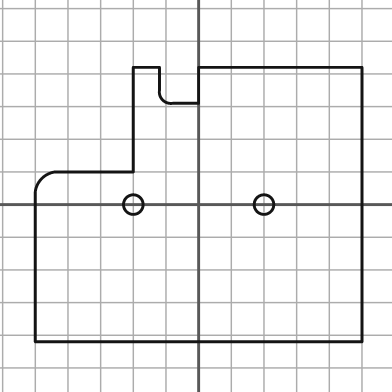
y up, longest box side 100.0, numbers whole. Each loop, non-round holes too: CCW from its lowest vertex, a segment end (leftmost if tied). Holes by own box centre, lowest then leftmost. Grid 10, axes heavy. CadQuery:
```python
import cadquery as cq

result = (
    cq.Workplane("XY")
    .moveTo(-50.0, -42.0)
    .lineTo(50.0, -42.0)
    .lineTo(50.0, 42.0)
    .lineTo(0.0, 42.0)
    .lineTo(0.0, 31.0)
    .lineTo(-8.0, 31.0)
    .threePointArc((-11.0, 32.0), (-12.0, 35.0))
    .lineTo(-12.0, 42.0)
    .lineTo(-20.0, 42.0)
    .lineTo(-20.0, 10.0)
    .lineTo(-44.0, 10.0)
    .threePointArc((-48.0, 8.0), (-50.0, 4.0))
    .close()
    .moveTo(-20.0, 0.0)
    .circle(3.0)
    .moveTo(20.0, 0.0)
    .circle(3.0)
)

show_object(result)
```